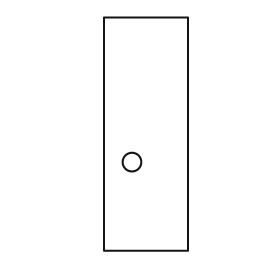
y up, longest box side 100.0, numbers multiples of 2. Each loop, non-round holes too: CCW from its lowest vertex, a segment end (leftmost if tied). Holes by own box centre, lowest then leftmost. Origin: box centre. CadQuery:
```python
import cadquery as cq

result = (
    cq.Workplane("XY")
    .moveTo(-18.0, -50.0)
    .lineTo(18.0, -50.0)
    .lineTo(18.0, 50.0)
    .lineTo(-18.0, 50.0)
    .close()
    .moveTo(-6.0, -12.0)
    .circle(4.0)
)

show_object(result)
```